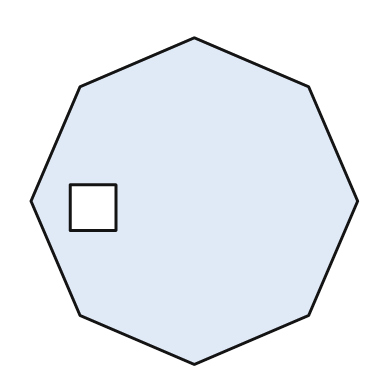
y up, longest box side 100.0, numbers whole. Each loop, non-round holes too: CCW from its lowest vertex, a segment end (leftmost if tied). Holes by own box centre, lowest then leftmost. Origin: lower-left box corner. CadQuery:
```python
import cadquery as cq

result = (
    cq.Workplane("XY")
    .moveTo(50.0, 0.0)
    .lineTo(85.0, 15.0)
    .lineTo(100.0, 50.0)
    .lineTo(85.0, 85.0)
    .lineTo(50.0, 100.0)
    .lineTo(15.0, 85.0)
    .lineTo(0.0, 50.0)
    .lineTo(15.0, 15.0)
    .close()
    .moveTo(12.0, 41.0)
    .lineTo(26.0, 41.0)
    .lineTo(26.0, 55.0)
    .lineTo(12.0, 55.0)
    .close()
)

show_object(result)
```